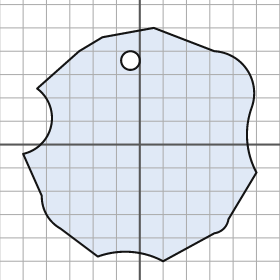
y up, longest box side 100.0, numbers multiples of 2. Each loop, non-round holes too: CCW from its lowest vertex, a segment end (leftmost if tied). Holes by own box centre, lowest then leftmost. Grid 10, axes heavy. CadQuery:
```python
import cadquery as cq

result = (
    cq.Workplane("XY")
    .moveTo(10.0, -50.0)
    .lineTo(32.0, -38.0)
    .threePointArc((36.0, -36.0), (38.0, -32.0))
    .lineTo(50.0, -12.0)
    .threePointArc((46.0, 2.0), (48.0, 16.0))
    .threePointArc((46.0, 32.0), (32.0, 40.0))
    .lineTo(6.0, 50.0)
    .lineTo(-16.0, 46.0)
    .lineTo(-26.0, 40.0)
    .lineTo(-44.0, 24.0)
    .threePointArc((-38.0, 8.0), (-50.0, -4.0))
    .lineTo(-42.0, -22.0)
    .threePointArc((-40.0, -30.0), (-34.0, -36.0))
    .lineTo(-18.0, -48.0)
    .threePointArc((-4.0, -46.0), (10.0, -50.0))
    .close()
    .moveTo(-4.0, 36.0)
    .circle(4.0)
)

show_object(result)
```